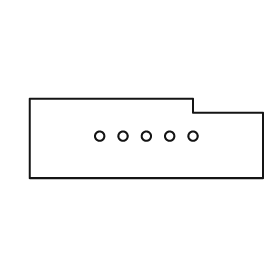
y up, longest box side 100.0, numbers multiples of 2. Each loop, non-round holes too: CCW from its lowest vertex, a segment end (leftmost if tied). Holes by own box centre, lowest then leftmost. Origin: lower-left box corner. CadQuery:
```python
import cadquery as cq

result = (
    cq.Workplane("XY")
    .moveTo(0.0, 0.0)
    .lineTo(100.0, 0.0)
    .lineTo(100.0, 28.0)
    .lineTo(70.0, 28.0)
    .lineTo(70.0, 34.0)
    .lineTo(0.0, 34.0)
    .close()
    .moveTo(30.0, 18.0)
    .circle(2.0)
    .moveTo(40.0, 18.0)
    .circle(2.0)
    .moveTo(50.0, 18.0)
    .circle(2.0)
    .moveTo(60.0, 18.0)
    .circle(2.0)
    .moveTo(70.0, 18.0)
    .circle(2.0)
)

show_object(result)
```